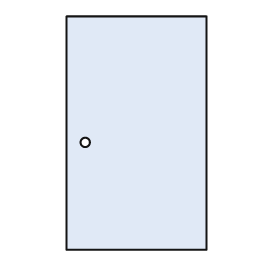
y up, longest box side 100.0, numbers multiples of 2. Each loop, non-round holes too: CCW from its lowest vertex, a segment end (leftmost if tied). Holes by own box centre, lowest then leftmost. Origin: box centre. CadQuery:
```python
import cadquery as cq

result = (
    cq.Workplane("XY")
    .moveTo(-30.0, -50.0)
    .lineTo(30.0, -50.0)
    .lineTo(30.0, 50.0)
    .lineTo(-30.0, 50.0)
    .close()
    .moveTo(-22.0, -4.0)
    .circle(2.0)
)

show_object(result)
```